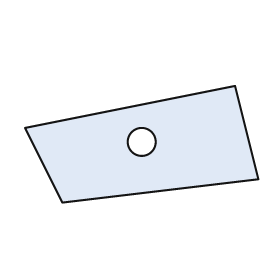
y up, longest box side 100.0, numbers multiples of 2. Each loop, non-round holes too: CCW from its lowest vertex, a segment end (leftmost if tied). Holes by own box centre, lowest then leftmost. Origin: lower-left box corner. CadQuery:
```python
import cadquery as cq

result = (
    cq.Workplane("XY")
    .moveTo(16.0, 0.0)
    .lineTo(100.0, 10.0)
    .lineTo(90.0, 50.0)
    .lineTo(0.0, 32.0)
    .close()
    .moveTo(50.0, 26.0)
    .circle(6.0)
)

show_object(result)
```